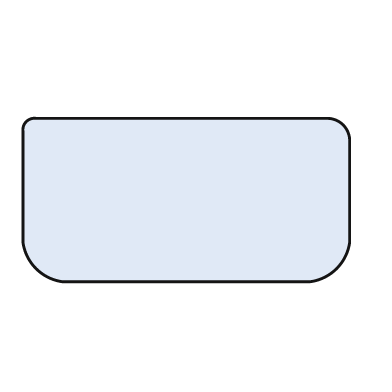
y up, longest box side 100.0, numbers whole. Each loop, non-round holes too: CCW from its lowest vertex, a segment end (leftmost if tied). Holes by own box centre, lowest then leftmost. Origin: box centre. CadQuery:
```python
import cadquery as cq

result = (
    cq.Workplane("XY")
    .moveTo(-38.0, -25.0)
    .lineTo(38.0, -25.0)
    .threePointArc((46.0, -21.0), (50.0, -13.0))
    .lineTo(50.0, 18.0)
    .threePointArc((48.0, 23.0), (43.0, 25.0))
    .lineTo(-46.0, 25.0)
    .threePointArc((-49.0, 24.0), (-50.0, 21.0))
    .lineTo(-50.0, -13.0)
    .threePointArc((-46.0, -21.0), (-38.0, -25.0))
    .close()
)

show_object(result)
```